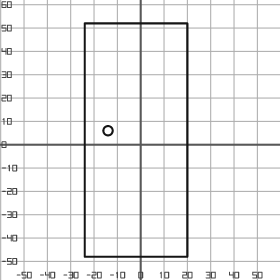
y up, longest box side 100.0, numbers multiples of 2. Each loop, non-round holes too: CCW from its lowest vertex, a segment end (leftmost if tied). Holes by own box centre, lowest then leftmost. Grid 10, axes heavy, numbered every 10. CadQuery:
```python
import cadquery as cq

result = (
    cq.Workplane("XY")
    .moveTo(-24.0, -48.0)
    .lineTo(20.0, -48.0)
    .lineTo(20.0, 52.0)
    .lineTo(-24.0, 52.0)
    .close()
    .moveTo(-14.0, 6.0)
    .circle(2.0)
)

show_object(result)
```